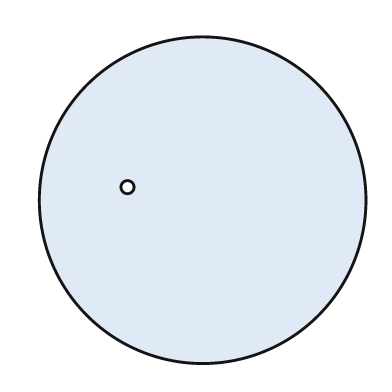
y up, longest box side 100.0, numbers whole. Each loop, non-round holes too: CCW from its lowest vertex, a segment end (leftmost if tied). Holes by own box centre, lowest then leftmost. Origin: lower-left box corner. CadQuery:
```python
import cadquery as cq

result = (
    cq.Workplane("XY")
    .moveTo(50.0, 50.0)
    .circle(50.0)
    .moveTo(27.0, 54.0)
    .circle(2.0)
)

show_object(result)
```